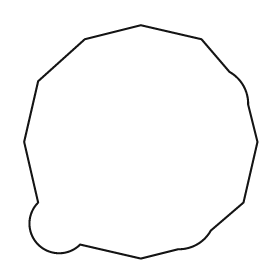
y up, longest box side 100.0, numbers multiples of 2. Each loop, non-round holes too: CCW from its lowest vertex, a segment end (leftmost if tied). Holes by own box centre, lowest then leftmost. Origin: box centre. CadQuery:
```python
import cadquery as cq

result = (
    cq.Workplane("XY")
    .moveTo(0.0, -50.0)
    .lineTo(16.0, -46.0)
    .threePointArc((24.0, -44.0), (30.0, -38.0))
    .lineTo(44.0, -26.0)
    .lineTo(50.0, 0.0)
    .lineTo(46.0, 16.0)
    .threePointArc((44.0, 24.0), (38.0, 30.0))
    .lineTo(26.0, 44.0)
    .lineTo(0.0, 50.0)
    .lineTo(-24.0, 44.0)
    .lineTo(-44.0, 26.0)
    .lineTo(-50.0, 0.0)
    .lineTo(-44.0, -26.0)
    .threePointArc((-44.0, -44.0), (-26.0, -44.0))
    .close()
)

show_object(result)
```